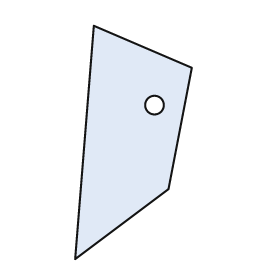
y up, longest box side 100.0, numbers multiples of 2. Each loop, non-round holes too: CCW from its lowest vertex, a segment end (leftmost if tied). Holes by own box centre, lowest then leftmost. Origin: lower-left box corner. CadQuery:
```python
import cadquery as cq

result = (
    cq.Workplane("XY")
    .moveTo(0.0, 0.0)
    .lineTo(40.0, 30.0)
    .lineTo(50.0, 82.0)
    .lineTo(8.0, 100.0)
    .close()
    .moveTo(34.0, 66.0)
    .circle(4.0)
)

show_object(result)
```